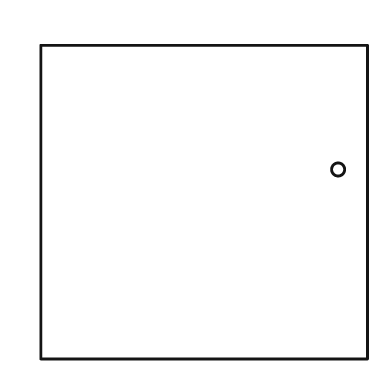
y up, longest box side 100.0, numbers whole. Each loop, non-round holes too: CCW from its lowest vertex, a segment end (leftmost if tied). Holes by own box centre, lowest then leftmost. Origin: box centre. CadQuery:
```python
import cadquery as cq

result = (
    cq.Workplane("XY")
    .moveTo(-50.0, -48.0)
    .lineTo(50.0, -48.0)
    .lineTo(50.0, 48.0)
    .lineTo(-50.0, 48.0)
    .close()
    .moveTo(41.0, 10.0)
    .circle(2.0)
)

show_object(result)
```